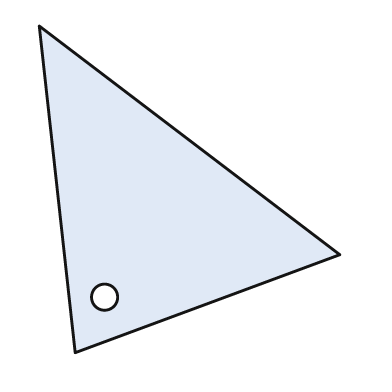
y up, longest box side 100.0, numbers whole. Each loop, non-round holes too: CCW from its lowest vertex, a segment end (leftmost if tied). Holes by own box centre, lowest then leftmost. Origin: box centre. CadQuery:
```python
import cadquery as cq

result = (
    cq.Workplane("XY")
    .moveTo(-35.0, -50.0)
    .lineTo(46.0, -20.0)
    .lineTo(-46.0, 50.0)
    .close()
    .moveTo(-26.0, -33.0)
    .circle(4.0)
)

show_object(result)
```